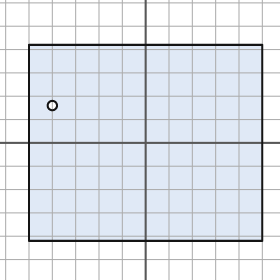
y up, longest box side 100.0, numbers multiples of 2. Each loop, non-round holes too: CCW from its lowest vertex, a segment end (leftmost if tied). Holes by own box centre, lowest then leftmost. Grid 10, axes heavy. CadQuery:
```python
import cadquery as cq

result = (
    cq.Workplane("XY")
    .moveTo(-50.0, -42.0)
    .lineTo(50.0, -42.0)
    .lineTo(50.0, 42.0)
    .lineTo(-50.0, 42.0)
    .close()
    .moveTo(-40.0, 16.0)
    .circle(2.0)
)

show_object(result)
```